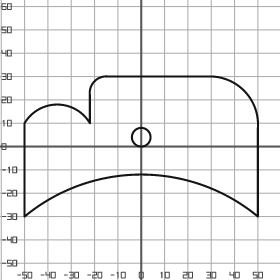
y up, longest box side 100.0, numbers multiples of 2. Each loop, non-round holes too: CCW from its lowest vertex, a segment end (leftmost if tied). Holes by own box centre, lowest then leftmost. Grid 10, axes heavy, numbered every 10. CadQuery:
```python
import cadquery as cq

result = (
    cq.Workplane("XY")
    .moveTo(-50.0, -30.0)
    .threePointArc((0.0, -12.0), (50.0, -30.0))
    .lineTo(50.0, 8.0)
    .threePointArc((44.0, 24.0), (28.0, 30.0))
    .lineTo(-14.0, 30.0)
    .threePointArc((-20.0, 28.0), (-22.0, 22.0))
    .lineTo(-22.0, 10.0)
    .threePointArc((-36.0, 18.0), (-50.0, 10.0))
    .close()
    .moveTo(0.0, 4.0)
    .circle(4.0)
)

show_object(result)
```